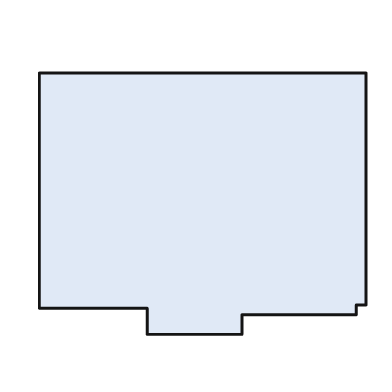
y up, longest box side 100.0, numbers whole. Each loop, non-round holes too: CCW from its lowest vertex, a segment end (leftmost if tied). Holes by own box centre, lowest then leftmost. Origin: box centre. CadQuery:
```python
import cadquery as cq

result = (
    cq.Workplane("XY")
    .moveTo(-17.0, -40.0)
    .lineTo(12.0, -40.0)
    .lineTo(12.0, -34.0)
    .lineTo(47.0, -34.0)
    .lineTo(47.0, -31.0)
    .lineTo(50.0, -31.0)
    .lineTo(50.0, 40.0)
    .lineTo(-50.0, 40.0)
    .lineTo(-50.0, -32.0)
    .lineTo(-17.0, -32.0)
    .close()
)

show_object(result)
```